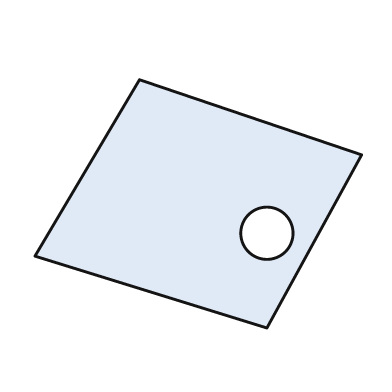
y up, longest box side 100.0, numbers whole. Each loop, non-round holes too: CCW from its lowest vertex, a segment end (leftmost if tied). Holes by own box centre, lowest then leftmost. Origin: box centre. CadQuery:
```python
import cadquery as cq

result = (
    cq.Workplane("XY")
    .moveTo(21.0, -38.0)
    .lineTo(50.0, 15.0)
    .lineTo(-18.0, 38.0)
    .lineTo(-50.0, -16.0)
    .close()
    .moveTo(21.0, -9.0)
    .circle(8.0)
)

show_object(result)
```